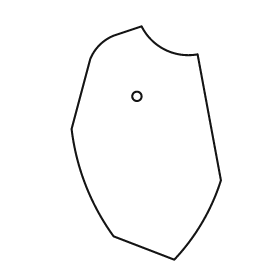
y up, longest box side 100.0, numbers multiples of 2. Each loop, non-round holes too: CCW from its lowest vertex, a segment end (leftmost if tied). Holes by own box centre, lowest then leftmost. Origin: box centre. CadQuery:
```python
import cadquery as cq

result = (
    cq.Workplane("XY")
    .moveTo(12.0, -50.0)
    .threePointArc((24.0, -34.0), (32.0, -16.0))
    .lineTo(22.0, 38.0)
    .threePointArc((8.0, 40.0), (-2.0, 50.0))
    .lineTo(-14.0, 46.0)
    .threePointArc((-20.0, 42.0), (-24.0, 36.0))
    .lineTo(-32.0, 6.0)
    .threePointArc((-26.0, -18.0), (-14.0, -40.0))
    .close()
    .moveTo(-4.0, 20.0)
    .circle(2.0)
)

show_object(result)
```